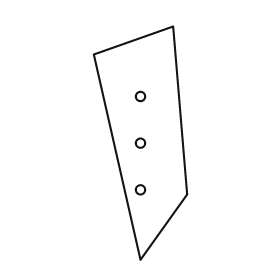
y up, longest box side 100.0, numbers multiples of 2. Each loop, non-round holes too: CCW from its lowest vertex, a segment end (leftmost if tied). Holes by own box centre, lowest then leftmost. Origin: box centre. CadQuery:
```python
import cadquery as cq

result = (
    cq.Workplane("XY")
    .moveTo(0.0, -50.0)
    .lineTo(20.0, -22.0)
    .lineTo(14.0, 50.0)
    .lineTo(-20.0, 38.0)
    .close()
    .moveTo(0.0, -20.0)
    .circle(2.0)
    .moveTo(0.0, 0.0)
    .circle(2.0)
    .moveTo(0.0, 20.0)
    .circle(2.0)
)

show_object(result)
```